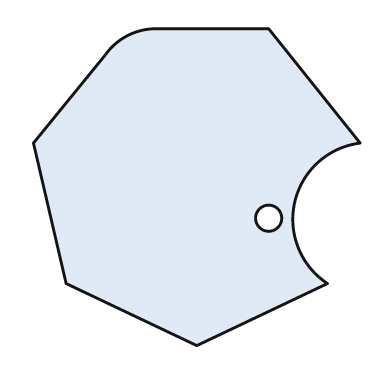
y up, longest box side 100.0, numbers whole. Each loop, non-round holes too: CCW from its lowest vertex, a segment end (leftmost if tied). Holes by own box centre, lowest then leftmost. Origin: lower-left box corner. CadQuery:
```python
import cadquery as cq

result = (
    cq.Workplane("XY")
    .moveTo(50.0, 0.0)
    .lineTo(90.0, 19.0)
    .threePointArc((80.0, 44.0), (100.0, 62.0))
    .lineTo(72.0, 97.0)
    .lineTo(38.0, 97.0)
    .threePointArc((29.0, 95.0), (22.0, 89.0))
    .lineTo(0.0, 62.0)
    .lineTo(10.0, 19.0)
    .close()
    .moveTo(72.0, 39.0)
    .circle(4.0)
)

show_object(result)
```